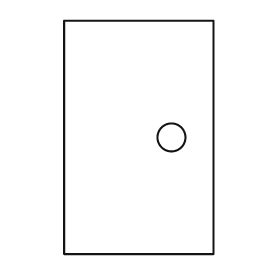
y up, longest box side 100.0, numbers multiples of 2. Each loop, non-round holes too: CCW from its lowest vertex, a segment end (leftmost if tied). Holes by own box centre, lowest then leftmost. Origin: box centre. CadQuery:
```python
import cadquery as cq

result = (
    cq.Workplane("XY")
    .moveTo(-32.0, -50.0)
    .lineTo(32.0, -50.0)
    .lineTo(32.0, 50.0)
    .lineTo(-32.0, 50.0)
    .close()
    .moveTo(14.0, 0.0)
    .circle(6.0)
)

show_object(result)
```